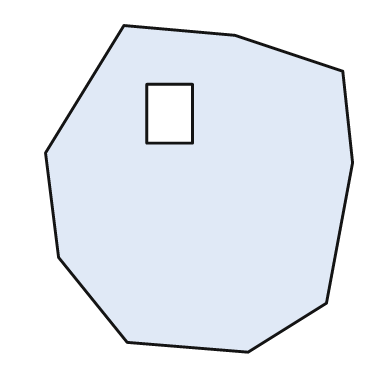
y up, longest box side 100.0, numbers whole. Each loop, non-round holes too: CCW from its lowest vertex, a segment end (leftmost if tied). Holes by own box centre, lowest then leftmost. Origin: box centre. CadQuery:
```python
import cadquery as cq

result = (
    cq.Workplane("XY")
    .moveTo(15.0, -50.0)
    .lineTo(39.0, -35.0)
    .lineTo(47.0, 8.0)
    .lineTo(44.0, 36.0)
    .lineTo(11.0, 47.0)
    .lineTo(-23.0, 50.0)
    .lineTo(-47.0, 11.0)
    .lineTo(-43.0, -21.0)
    .lineTo(-22.0, -47.0)
    .close()
    .moveTo(-16.0, 14.0)
    .lineTo(-2.0, 14.0)
    .lineTo(-2.0, 32.0)
    .lineTo(-16.0, 32.0)
    .close()
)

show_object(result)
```